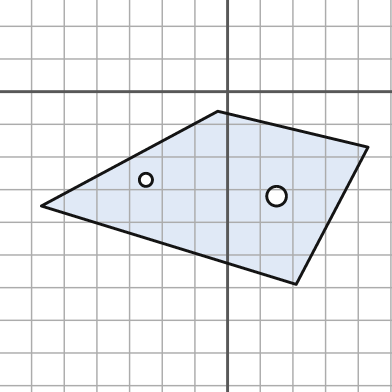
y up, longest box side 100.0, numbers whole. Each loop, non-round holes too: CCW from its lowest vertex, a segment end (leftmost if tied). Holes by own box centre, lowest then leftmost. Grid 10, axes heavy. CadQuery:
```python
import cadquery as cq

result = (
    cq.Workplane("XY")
    .moveTo(21.0, -59.0)
    .lineTo(43.0, -17.0)
    .lineTo(-3.0, -6.0)
    .lineTo(-57.0, -35.0)
    .close()
    .moveTo(15.0, -32.0)
    .circle(3.0)
    .moveTo(-25.0, -27.0)
    .circle(2.0)
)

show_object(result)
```